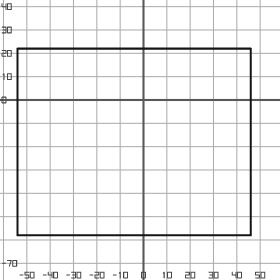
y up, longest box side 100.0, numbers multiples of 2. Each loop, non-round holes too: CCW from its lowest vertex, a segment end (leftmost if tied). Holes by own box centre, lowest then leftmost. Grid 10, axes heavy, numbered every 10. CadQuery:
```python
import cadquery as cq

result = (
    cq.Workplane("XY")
    .moveTo(-54.0, -58.0)
    .lineTo(46.0, -58.0)
    .lineTo(46.0, 22.0)
    .lineTo(-54.0, 22.0)
    .close()
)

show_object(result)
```